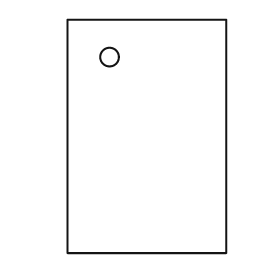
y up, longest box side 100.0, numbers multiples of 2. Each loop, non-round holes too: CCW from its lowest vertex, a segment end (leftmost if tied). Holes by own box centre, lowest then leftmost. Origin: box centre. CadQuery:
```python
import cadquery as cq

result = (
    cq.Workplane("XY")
    .moveTo(-34.0, -50.0)
    .lineTo(34.0, -50.0)
    .lineTo(34.0, 50.0)
    .lineTo(-34.0, 50.0)
    .close()
    .moveTo(-16.0, 34.0)
    .circle(4.0)
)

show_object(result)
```